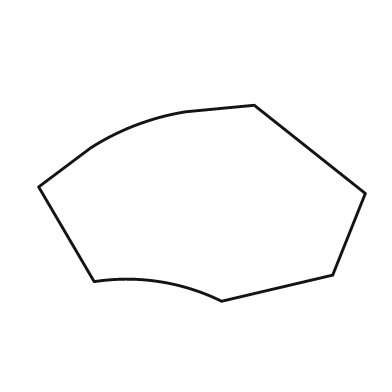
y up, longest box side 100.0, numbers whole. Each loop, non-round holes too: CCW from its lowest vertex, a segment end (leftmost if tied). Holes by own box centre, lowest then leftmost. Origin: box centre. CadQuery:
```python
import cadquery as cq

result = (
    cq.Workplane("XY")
    .moveTo(6.0, -30.0)
    .lineTo(40.0, -22.0)
    .lineTo(50.0, 3.0)
    .lineTo(16.0, 30.0)
    .lineTo(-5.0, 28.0)
    .threePointArc((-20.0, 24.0), (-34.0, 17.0))
    .lineTo(-50.0, 5.0)
    .lineTo(-33.0, -24.0)
    .threePointArc((-13.0, -24.0), (6.0, -30.0))
    .close()
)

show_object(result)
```